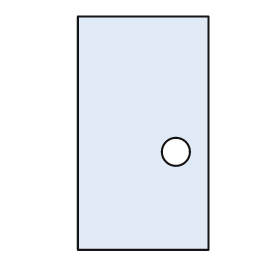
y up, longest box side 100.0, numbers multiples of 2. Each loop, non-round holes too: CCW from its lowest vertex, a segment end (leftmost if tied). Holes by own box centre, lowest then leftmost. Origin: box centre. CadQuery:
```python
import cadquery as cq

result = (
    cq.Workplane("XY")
    .moveTo(-28.0, -50.0)
    .lineTo(28.0, -50.0)
    .lineTo(28.0, 50.0)
    .lineTo(-28.0, 50.0)
    .close()
    .moveTo(14.0, -8.0)
    .circle(6.0)
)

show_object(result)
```